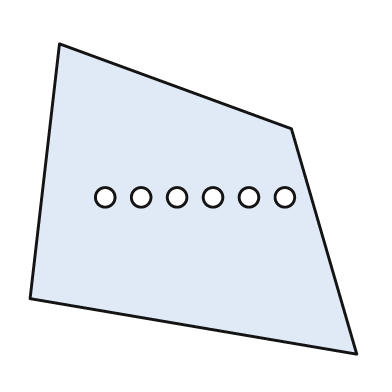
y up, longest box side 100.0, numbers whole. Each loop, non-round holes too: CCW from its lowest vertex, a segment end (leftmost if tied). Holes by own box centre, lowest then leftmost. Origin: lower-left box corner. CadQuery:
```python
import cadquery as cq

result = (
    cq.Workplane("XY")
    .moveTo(100.0, 0.0)
    .lineTo(80.0, 69.0)
    .lineTo(9.0, 95.0)
    .lineTo(0.0, 17.0)
    .close()
    .moveTo(23.0, 48.0)
    .circle(3.0)
    .moveTo(34.0, 48.0)
    .circle(3.0)
    .moveTo(45.0, 48.0)
    .circle(3.0)
    .moveTo(56.0, 48.0)
    .circle(3.0)
    .moveTo(67.0, 48.0)
    .circle(3.0)
    .moveTo(78.0, 48.0)
    .circle(3.0)
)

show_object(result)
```